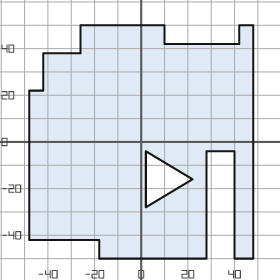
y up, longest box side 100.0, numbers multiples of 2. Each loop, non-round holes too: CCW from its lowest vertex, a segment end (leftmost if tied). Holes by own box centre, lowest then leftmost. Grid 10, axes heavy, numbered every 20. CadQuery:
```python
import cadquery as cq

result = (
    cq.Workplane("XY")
    .moveTo(-18.0, -50.0)
    .lineTo(28.0, -50.0)
    .lineTo(28.0, -4.0)
    .lineTo(40.0, -4.0)
    .lineTo(40.0, -50.0)
    .lineTo(48.0, -50.0)
    .lineTo(48.0, 50.0)
    .lineTo(42.0, 50.0)
    .lineTo(42.0, 42.0)
    .lineTo(10.0, 42.0)
    .lineTo(10.0, 50.0)
    .lineTo(-26.0, 50.0)
    .lineTo(-26.0, 38.0)
    .lineTo(-42.0, 38.0)
    .lineTo(-42.0, 22.0)
    .lineTo(-48.0, 22.0)
    .lineTo(-48.0, -42.0)
    .lineTo(-18.0, -42.0)
    .close()
    .moveTo(2.0, -28.0)
    .lineTo(22.0, -16.0)
    .lineTo(2.0, -4.0)
    .close()
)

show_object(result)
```